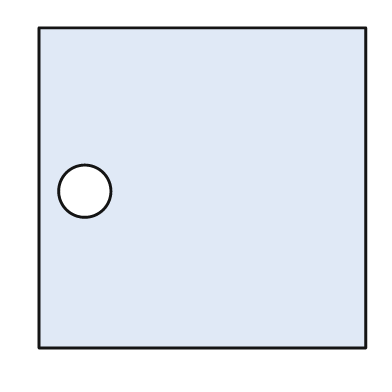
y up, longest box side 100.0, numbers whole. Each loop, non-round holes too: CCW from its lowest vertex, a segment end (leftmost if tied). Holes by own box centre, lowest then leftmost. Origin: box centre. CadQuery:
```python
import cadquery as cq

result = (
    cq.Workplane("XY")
    .moveTo(-50.0, -49.0)
    .lineTo(50.0, -49.0)
    .lineTo(50.0, 49.0)
    .lineTo(-50.0, 49.0)
    .close()
    .moveTo(-36.0, -1.0)
    .circle(8.0)
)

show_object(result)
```